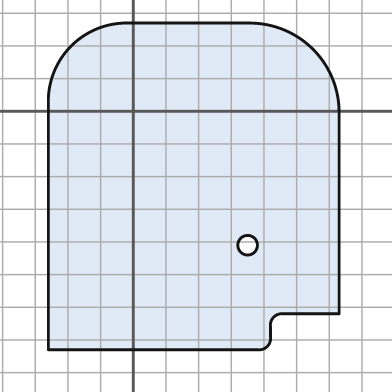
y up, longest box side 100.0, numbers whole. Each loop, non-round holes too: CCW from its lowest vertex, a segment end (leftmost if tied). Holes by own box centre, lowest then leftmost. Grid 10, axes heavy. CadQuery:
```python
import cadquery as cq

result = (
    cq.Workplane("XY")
    .moveTo(-26.0, -73.0)
    .lineTo(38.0, -73.0)
    .threePointArc((41.0, -72.0), (42.0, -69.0))
    .lineTo(42.0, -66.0)
    .threePointArc((43.0, -63.0), (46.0, -62.0))
    .lineTo(63.0, -62.0)
    .lineTo(63.0, 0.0)
    .threePointArc((55.0, 19.0), (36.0, 27.0))
    .lineTo(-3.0, 27.0)
    .threePointArc((-19.0, 20.0), (-26.0, 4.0))
    .close()
    .moveTo(35.0, -41.0)
    .circle(3.0)
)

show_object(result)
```